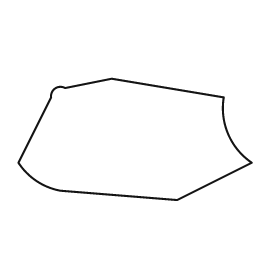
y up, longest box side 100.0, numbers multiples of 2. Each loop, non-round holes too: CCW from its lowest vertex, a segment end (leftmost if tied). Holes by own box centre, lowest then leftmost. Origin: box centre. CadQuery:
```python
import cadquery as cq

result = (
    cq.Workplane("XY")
    .moveTo(18.0, -26.0)
    .lineTo(50.0, -10.0)
    .threePointArc((40.0, 2.0), (38.0, 18.0))
    .lineTo(-10.0, 26.0)
    .lineTo(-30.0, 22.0)
    .threePointArc((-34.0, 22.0), (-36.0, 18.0))
    .lineTo(-50.0, -10.0)
    .threePointArc((-42.0, -18.0), (-32.0, -22.0))
    .close()
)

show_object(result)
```